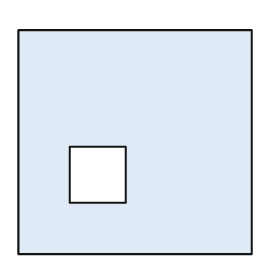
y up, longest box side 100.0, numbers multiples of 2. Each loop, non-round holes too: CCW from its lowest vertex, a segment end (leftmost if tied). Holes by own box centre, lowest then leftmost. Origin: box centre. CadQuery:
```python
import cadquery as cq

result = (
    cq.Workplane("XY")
    .moveTo(-50.0, -48.0)
    .lineTo(50.0, -48.0)
    .lineTo(50.0, 48.0)
    .lineTo(-50.0, 48.0)
    .close()
    .moveTo(-28.0, -26.0)
    .lineTo(-4.0, -26.0)
    .lineTo(-4.0, -2.0)
    .lineTo(-28.0, -2.0)
    .close()
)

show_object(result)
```